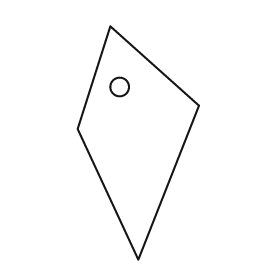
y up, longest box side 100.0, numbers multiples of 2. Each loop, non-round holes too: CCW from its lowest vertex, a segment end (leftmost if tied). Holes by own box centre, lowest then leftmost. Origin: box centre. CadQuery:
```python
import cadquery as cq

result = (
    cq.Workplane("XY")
    .moveTo(0.0, -50.0)
    .lineTo(26.0, 16.0)
    .lineTo(-12.0, 50.0)
    .lineTo(-26.0, 6.0)
    .close()
    .moveTo(-8.0, 24.0)
    .circle(4.0)
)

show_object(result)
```